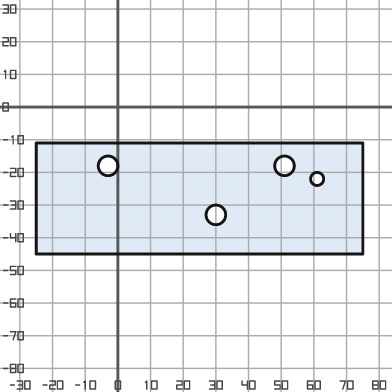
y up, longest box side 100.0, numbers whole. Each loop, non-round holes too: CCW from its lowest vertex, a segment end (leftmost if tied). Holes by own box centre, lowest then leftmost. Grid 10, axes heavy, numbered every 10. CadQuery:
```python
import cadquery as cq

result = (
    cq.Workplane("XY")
    .moveTo(-25.0, -45.0)
    .lineTo(75.0, -45.0)
    .lineTo(75.0, -11.0)
    .lineTo(-25.0, -11.0)
    .close()
    .moveTo(30.0, -33.0)
    .circle(3.0)
    .moveTo(61.0, -22.0)
    .circle(2.0)
    .moveTo(-3.0, -18.0)
    .circle(3.0)
    .moveTo(51.0, -18.0)
    .circle(3.0)
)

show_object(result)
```